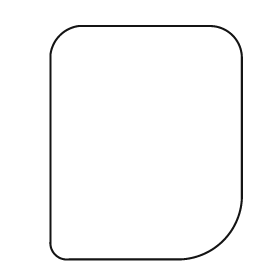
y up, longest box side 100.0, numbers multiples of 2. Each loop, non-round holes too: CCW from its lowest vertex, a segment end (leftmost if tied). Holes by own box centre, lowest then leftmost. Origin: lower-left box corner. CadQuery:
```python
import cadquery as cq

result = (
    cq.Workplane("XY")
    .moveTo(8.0, 0.0)
    .lineTo(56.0, 0.0)
    .threePointArc((74.0, 8.0), (82.0, 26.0))
    .lineTo(82.0, 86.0)
    .threePointArc((78.0, 96.0), (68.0, 100.0))
    .lineTo(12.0, 100.0)
    .threePointArc((4.0, 96.0), (0.0, 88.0))
    .lineTo(0.0, 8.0)
    .threePointArc((2.0, 2.0), (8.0, 0.0))
    .close()
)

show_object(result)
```